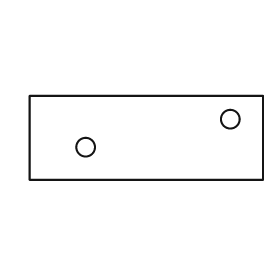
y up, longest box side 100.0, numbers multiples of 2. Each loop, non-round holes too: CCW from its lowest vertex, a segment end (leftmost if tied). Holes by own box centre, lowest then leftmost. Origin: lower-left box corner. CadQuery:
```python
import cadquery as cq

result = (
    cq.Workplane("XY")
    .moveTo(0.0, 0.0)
    .lineTo(100.0, 0.0)
    .lineTo(100.0, 36.0)
    .lineTo(0.0, 36.0)
    .close()
    .moveTo(24.0, 14.0)
    .circle(4.0)
    .moveTo(86.0, 26.0)
    .circle(4.0)
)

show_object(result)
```